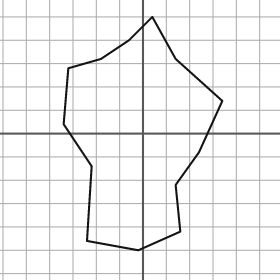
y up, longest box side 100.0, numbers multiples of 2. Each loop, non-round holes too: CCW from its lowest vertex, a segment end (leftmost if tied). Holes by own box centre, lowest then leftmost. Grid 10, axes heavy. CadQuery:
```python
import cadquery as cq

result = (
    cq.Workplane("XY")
    .moveTo(-2.0, -50.0)
    .lineTo(16.0, -42.0)
    .lineTo(14.0, -22.0)
    .lineTo(24.0, -8.0)
    .lineTo(34.0, 14.0)
    .lineTo(14.0, 32.0)
    .lineTo(4.0, 50.0)
    .lineTo(-6.0, 40.0)
    .lineTo(-18.0, 32.0)
    .lineTo(-32.0, 28.0)
    .lineTo(-34.0, 4.0)
    .lineTo(-22.0, -14.0)
    .lineTo(-24.0, -46.0)
    .close()
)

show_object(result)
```